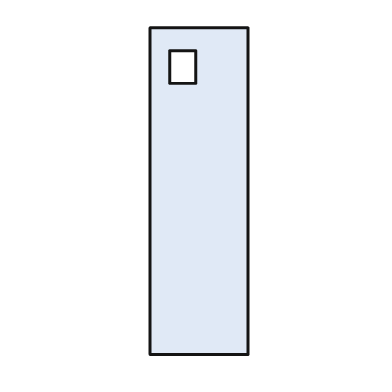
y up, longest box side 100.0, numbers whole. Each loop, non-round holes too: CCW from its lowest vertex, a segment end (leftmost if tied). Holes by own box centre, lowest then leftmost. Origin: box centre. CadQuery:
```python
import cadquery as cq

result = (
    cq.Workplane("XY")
    .moveTo(-15.0, -50.0)
    .lineTo(15.0, -50.0)
    .lineTo(15.0, 50.0)
    .lineTo(-15.0, 50.0)
    .close()
    .moveTo(-9.0, 33.0)
    .lineTo(-1.0, 33.0)
    .lineTo(-1.0, 43.0)
    .lineTo(-9.0, 43.0)
    .close()
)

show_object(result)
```